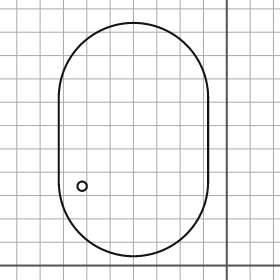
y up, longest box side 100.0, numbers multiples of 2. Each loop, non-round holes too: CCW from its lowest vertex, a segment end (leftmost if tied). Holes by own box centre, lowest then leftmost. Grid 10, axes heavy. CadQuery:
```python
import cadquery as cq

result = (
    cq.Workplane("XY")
    .moveTo(-72.0, 36.0)
    .threePointArc((-40.0, 4.0), (-8.0, 36.0))
    .lineTo(-8.0, 72.0)
    .threePointArc((-40.0, 104.0), (-72.0, 72.0))
    .close()
    .moveTo(-62.0, 34.0)
    .circle(2.0)
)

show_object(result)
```